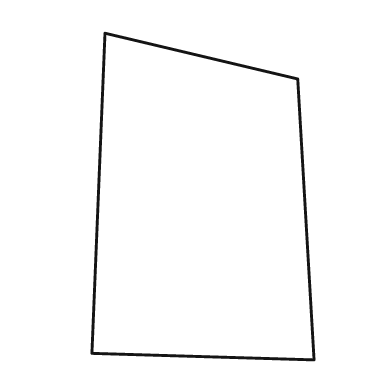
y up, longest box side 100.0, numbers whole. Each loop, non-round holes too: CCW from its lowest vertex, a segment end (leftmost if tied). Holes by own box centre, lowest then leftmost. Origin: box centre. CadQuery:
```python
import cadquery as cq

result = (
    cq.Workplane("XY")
    .moveTo(34.0, -50.0)
    .lineTo(29.0, 36.0)
    .lineTo(-30.0, 50.0)
    .lineTo(-34.0, -48.0)
    .close()
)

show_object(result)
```